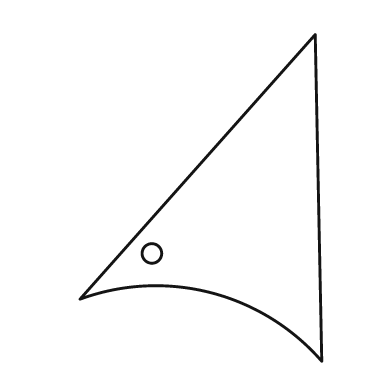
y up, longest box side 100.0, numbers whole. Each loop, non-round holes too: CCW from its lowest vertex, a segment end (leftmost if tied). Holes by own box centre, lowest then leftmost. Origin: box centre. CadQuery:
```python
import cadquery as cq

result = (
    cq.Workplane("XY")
    .moveTo(37.0, -50.0)
    .lineTo(35.0, 50.0)
    .lineTo(-37.0, -31.0)
    .threePointArc((3.0, -29.0), (37.0, -50.0))
    .close()
    .moveTo(-15.0, -17.0)
    .circle(3.0)
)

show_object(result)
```